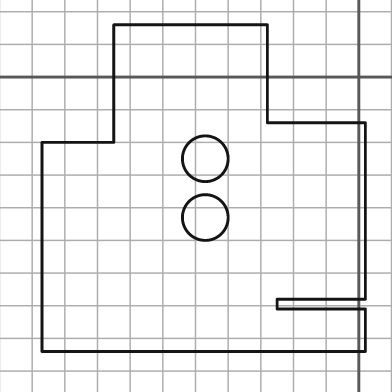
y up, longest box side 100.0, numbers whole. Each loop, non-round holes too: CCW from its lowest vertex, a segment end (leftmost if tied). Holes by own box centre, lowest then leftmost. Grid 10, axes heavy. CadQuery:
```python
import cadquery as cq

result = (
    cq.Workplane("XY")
    .moveTo(-97.0, -84.0)
    .lineTo(2.0, -84.0)
    .lineTo(2.0, -71.0)
    .lineTo(-25.0, -71.0)
    .lineTo(-25.0, -68.0)
    .lineTo(2.0, -68.0)
    .lineTo(2.0, -14.0)
    .lineTo(-28.0, -14.0)
    .lineTo(-28.0, 16.0)
    .lineTo(-75.0, 16.0)
    .lineTo(-75.0, -20.0)
    .lineTo(-97.0, -20.0)
    .close()
    .moveTo(-47.0, -43.0)
    .circle(7.0)
    .moveTo(-47.0, -25.0)
    .circle(7.0)
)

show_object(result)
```